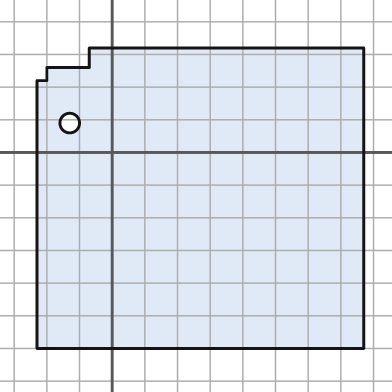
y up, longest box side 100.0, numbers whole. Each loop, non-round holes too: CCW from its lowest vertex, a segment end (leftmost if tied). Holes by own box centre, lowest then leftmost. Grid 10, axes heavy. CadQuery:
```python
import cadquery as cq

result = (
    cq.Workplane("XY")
    .moveTo(-23.0, -60.0)
    .lineTo(77.0, -60.0)
    .lineTo(77.0, 32.0)
    .lineTo(-7.0, 32.0)
    .lineTo(-7.0, 26.0)
    .lineTo(-20.0, 26.0)
    .lineTo(-20.0, 22.0)
    .lineTo(-23.0, 22.0)
    .close()
    .moveTo(-13.0, 9.0)
    .circle(3.0)
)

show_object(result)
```